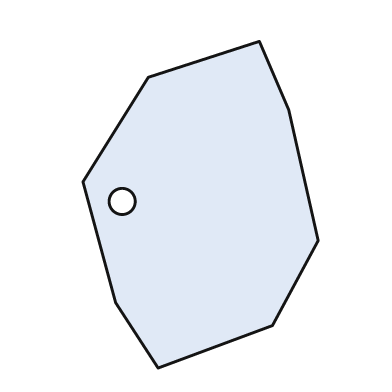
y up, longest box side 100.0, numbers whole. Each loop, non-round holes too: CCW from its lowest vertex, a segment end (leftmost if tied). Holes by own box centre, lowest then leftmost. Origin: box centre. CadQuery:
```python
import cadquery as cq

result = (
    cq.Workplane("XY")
    .moveTo(-13.0, -50.0)
    .lineTo(22.0, -37.0)
    .lineTo(36.0, -11.0)
    .lineTo(27.0, 29.0)
    .lineTo(18.0, 50.0)
    .lineTo(-16.0, 39.0)
    .lineTo(-36.0, 7.0)
    .lineTo(-26.0, -30.0)
    .close()
    .moveTo(-24.0, 1.0)
    .circle(4.0)
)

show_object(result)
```